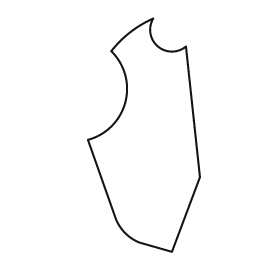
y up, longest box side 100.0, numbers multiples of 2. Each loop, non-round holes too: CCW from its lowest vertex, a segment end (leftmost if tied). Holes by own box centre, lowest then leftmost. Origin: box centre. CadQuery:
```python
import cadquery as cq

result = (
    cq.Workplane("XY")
    .moveTo(12.0, -50.0)
    .lineTo(24.0, -18.0)
    .lineTo(18.0, 38.0)
    .threePointArc((6.0, 38.0), (4.0, 50.0))
    .threePointArc((-6.0, 44.0), (-14.0, 36.0))
    .threePointArc((-8.0, 14.0), (-24.0, -2.0))
    .lineTo(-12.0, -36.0)
    .threePointArc((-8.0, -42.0), (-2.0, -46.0))
    .close()
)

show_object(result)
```